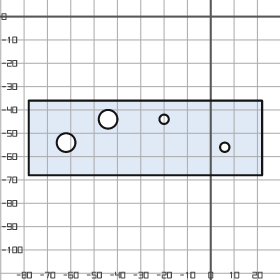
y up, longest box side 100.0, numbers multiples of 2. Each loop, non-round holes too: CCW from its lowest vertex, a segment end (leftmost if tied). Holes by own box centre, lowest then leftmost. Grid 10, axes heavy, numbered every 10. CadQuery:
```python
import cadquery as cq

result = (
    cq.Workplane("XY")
    .moveTo(-78.0, -68.0)
    .lineTo(22.0, -68.0)
    .lineTo(22.0, -36.0)
    .lineTo(-78.0, -36.0)
    .close()
    .moveTo(6.0, -56.0)
    .circle(2.0)
    .moveTo(-62.0, -54.0)
    .circle(4.0)
    .moveTo(-44.0, -44.0)
    .circle(4.0)
    .moveTo(-20.0, -44.0)
    .circle(2.0)
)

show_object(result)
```